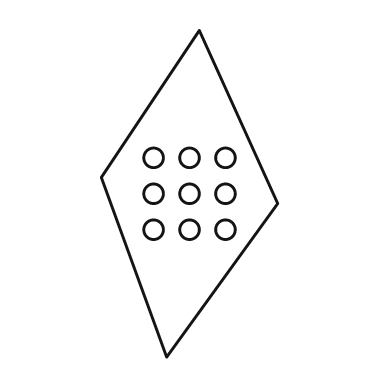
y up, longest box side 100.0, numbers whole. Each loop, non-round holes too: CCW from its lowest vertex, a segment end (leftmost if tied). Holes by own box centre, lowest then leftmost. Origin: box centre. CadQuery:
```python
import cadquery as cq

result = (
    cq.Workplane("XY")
    .moveTo(-7.0, -50.0)
    .lineTo(27.0, -3.0)
    .lineTo(3.0, 50.0)
    .lineTo(-27.0, 5.0)
    .close()
    .moveTo(-11.0, -11.0)
    .circle(3.0)
    .moveTo(0.0, -11.0)
    .circle(3.0)
    .moveTo(11.0, -11.0)
    .circle(3.0)
    .moveTo(-11.0, 0.0)
    .circle(3.0)
    .moveTo(0.0, 0.0)
    .circle(3.0)
    .moveTo(11.0, 0.0)
    .circle(3.0)
    .moveTo(-11.0, 11.0)
    .circle(3.0)
    .moveTo(0.0, 11.0)
    .circle(3.0)
    .moveTo(11.0, 11.0)
    .circle(3.0)
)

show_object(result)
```